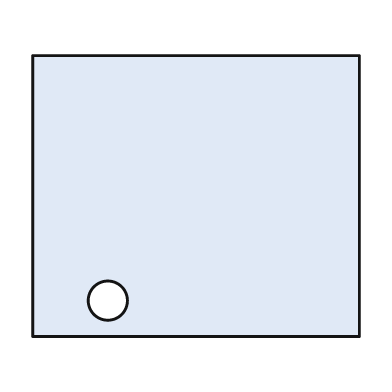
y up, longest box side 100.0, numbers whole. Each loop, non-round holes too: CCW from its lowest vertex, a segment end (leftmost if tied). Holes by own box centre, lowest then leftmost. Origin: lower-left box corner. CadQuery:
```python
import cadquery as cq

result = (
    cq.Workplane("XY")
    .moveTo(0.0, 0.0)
    .lineTo(100.0, 0.0)
    .lineTo(100.0, 86.0)
    .lineTo(0.0, 86.0)
    .close()
    .moveTo(23.0, 11.0)
    .circle(6.0)
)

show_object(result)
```